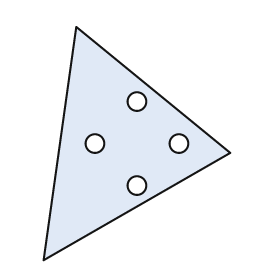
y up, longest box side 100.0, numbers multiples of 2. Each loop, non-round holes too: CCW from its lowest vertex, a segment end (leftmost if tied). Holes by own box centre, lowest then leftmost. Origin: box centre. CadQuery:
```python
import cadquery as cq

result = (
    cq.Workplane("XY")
    .moveTo(-40.0, -50.0)
    .lineTo(40.0, -4.0)
    .lineTo(-26.0, 50.0)
    .close()
    .moveTo(0.0, -18.0)
    .circle(4.0)
    .moveTo(-18.0, 0.0)
    .circle(4.0)
    .moveTo(18.0, 0.0)
    .circle(4.0)
    .moveTo(0.0, 18.0)
    .circle(4.0)
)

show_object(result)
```